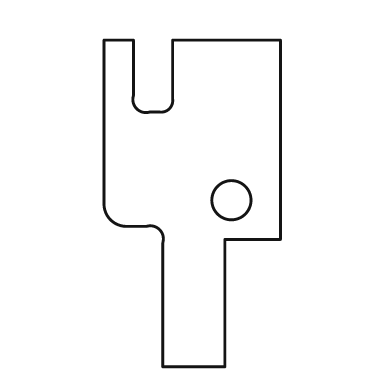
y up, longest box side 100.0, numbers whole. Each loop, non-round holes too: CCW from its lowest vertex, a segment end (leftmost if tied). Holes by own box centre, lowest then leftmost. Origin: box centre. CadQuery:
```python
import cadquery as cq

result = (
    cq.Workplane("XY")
    .moveTo(-9.0, -50.0)
    .lineTo(10.0, -50.0)
    .lineTo(10.0, -11.0)
    .lineTo(27.0, -11.0)
    .lineTo(27.0, 50.0)
    .lineTo(-6.0, 50.0)
    .lineTo(-6.0, 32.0)
    .threePointArc((-7.0, 29.0), (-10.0, 28.0))
    .lineTo(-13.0, 28.0)
    .threePointArc((-17.0, 29.0), (-18.0, 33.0))
    .lineTo(-18.0, 50.0)
    .lineTo(-27.0, 50.0)
    .lineTo(-27.0, 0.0)
    .threePointArc((-25.0, -5.0), (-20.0, -7.0))
    .lineTo(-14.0, -7.0)
    .threePointArc((-10.0, -8.0), (-9.0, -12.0))
    .close()
    .moveTo(12.0, 1.0)
    .circle(6.0)
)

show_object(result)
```